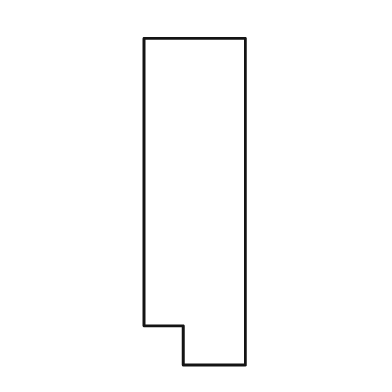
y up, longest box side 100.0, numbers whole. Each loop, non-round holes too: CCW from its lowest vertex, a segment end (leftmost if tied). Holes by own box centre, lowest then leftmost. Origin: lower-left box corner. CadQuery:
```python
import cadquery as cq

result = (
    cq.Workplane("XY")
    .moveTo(12.0, 0.0)
    .lineTo(31.0, 0.0)
    .lineTo(31.0, 100.0)
    .lineTo(0.0, 100.0)
    .lineTo(0.0, 12.0)
    .lineTo(12.0, 12.0)
    .close()
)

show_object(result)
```